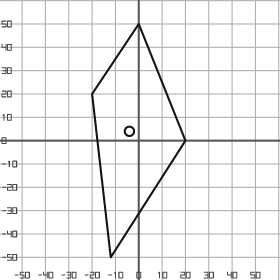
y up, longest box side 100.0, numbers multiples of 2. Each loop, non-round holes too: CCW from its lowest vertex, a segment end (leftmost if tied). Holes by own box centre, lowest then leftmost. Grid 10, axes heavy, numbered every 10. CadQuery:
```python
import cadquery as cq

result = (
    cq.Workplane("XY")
    .moveTo(-12.0, -50.0)
    .lineTo(20.0, 0.0)
    .lineTo(0.0, 50.0)
    .lineTo(-20.0, 20.0)
    .close()
    .moveTo(-4.0, 4.0)
    .circle(2.0)
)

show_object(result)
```